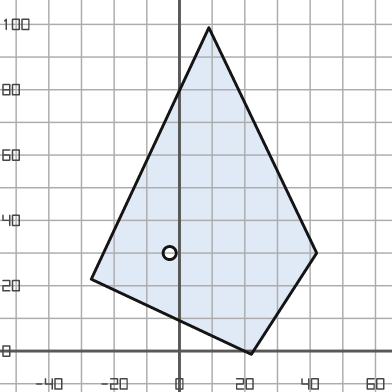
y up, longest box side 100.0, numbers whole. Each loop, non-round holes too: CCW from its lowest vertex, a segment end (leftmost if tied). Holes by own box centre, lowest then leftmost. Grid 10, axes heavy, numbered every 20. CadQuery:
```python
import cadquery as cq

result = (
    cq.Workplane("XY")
    .moveTo(22.0, -1.0)
    .lineTo(42.0, 30.0)
    .lineTo(9.0, 99.0)
    .lineTo(-27.0, 22.0)
    .close()
    .moveTo(-3.0, 30.0)
    .circle(2.0)
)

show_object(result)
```